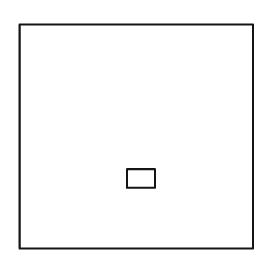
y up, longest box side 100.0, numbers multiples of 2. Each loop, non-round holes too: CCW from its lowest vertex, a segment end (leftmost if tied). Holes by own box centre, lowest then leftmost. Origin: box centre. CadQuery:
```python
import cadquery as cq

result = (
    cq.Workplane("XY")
    .moveTo(-50.0, -48.0)
    .lineTo(50.0, -48.0)
    .lineTo(50.0, 48.0)
    .lineTo(-50.0, 48.0)
    .close()
    .moveTo(-4.0, -22.0)
    .lineTo(8.0, -22.0)
    .lineTo(8.0, -14.0)
    .lineTo(-4.0, -14.0)
    .close()
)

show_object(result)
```